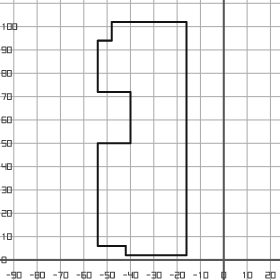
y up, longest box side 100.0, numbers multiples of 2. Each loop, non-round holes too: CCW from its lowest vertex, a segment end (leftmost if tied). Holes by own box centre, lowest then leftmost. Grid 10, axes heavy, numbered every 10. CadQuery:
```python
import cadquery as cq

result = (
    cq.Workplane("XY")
    .moveTo(-42.0, 2.0)
    .lineTo(-16.0, 2.0)
    .lineTo(-16.0, 102.0)
    .lineTo(-48.0, 102.0)
    .lineTo(-48.0, 94.0)
    .lineTo(-54.0, 94.0)
    .lineTo(-54.0, 72.0)
    .lineTo(-40.0, 72.0)
    .lineTo(-40.0, 50.0)
    .lineTo(-54.0, 50.0)
    .lineTo(-54.0, 6.0)
    .lineTo(-42.0, 6.0)
    .close()
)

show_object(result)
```